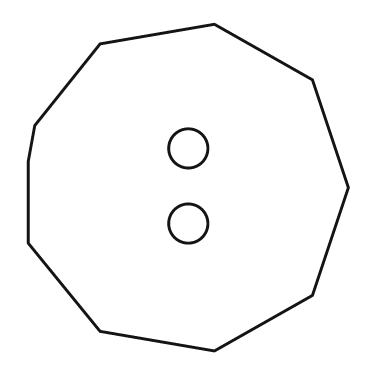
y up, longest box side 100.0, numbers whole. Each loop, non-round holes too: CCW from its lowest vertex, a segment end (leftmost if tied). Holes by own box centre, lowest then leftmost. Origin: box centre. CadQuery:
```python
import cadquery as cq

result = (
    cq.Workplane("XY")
    .moveTo(8.0, -50.0)
    .lineTo(38.0, -33.0)
    .lineTo(49.0, 0.0)
    .lineTo(38.0, 33.0)
    .lineTo(8.0, 50.0)
    .lineTo(-27.0, 44.0)
    .lineTo(-47.0, 19.0)
    .lineTo(-49.0, 8.0)
    .lineTo(-49.0, -17.0)
    .lineTo(-27.0, -44.0)
    .close()
    .moveTo(0.0, -11.0)
    .circle(6.0)
    .moveTo(0.0, 12.0)
    .circle(6.0)
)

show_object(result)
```